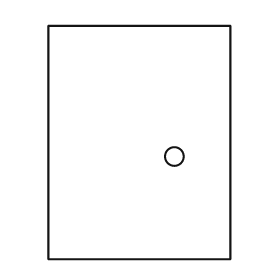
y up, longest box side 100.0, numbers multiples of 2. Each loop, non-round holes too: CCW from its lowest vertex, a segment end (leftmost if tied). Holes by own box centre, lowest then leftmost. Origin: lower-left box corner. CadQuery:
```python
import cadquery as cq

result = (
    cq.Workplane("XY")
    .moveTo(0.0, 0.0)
    .lineTo(78.0, 0.0)
    .lineTo(78.0, 100.0)
    .lineTo(0.0, 100.0)
    .close()
    .moveTo(54.0, 44.0)
    .circle(4.0)
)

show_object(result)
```